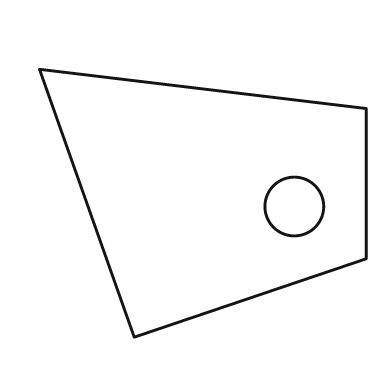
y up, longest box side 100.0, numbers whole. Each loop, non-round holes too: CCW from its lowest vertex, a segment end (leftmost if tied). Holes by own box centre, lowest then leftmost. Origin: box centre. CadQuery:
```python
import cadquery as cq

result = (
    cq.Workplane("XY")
    .moveTo(-21.0, -41.0)
    .lineTo(50.0, -17.0)
    .lineTo(50.0, 29.0)
    .lineTo(-50.0, 41.0)
    .close()
    .moveTo(28.0, -1.0)
    .circle(9.0)
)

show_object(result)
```